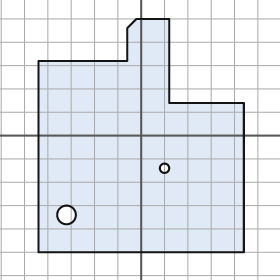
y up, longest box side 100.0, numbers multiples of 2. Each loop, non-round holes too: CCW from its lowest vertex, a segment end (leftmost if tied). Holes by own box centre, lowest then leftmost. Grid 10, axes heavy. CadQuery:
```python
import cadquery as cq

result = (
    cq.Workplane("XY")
    .moveTo(-44.0, -50.0)
    .lineTo(44.0, -50.0)
    .lineTo(44.0, 14.0)
    .lineTo(12.0, 14.0)
    .lineTo(12.0, 50.0)
    .lineTo(-2.0, 50.0)
    .lineTo(-6.0, 46.0)
    .lineTo(-6.0, 32.0)
    .lineTo(-44.0, 32.0)
    .close()
    .moveTo(-32.0, -34.0)
    .circle(4.0)
    .moveTo(10.0, -14.0)
    .circle(2.0)
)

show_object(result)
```